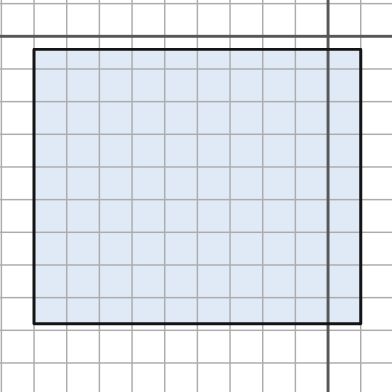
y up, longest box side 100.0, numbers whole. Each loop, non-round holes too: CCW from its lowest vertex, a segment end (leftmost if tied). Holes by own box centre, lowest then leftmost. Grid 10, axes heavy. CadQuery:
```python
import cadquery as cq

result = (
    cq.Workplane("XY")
    .moveTo(-90.0, -88.0)
    .lineTo(10.0, -88.0)
    .lineTo(10.0, -4.0)
    .lineTo(-90.0, -4.0)
    .close()
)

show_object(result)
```